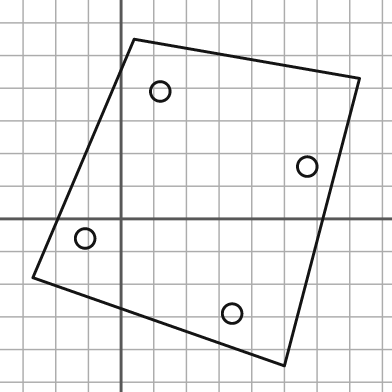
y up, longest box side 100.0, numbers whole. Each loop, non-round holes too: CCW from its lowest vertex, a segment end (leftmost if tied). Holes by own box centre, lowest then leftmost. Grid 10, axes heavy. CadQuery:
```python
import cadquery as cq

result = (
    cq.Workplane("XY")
    .moveTo(50.0, -45.0)
    .lineTo(73.0, 43.0)
    .lineTo(4.0, 55.0)
    .lineTo(-27.0, -18.0)
    .close()
    .moveTo(34.0, -29.0)
    .circle(3.0)
    .moveTo(-11.0, -6.0)
    .circle(3.0)
    .moveTo(57.0, 16.0)
    .circle(3.0)
    .moveTo(12.0, 39.0)
    .circle(3.0)
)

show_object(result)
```